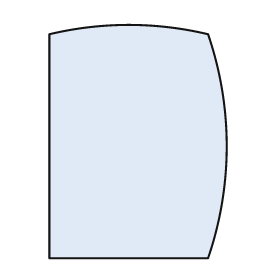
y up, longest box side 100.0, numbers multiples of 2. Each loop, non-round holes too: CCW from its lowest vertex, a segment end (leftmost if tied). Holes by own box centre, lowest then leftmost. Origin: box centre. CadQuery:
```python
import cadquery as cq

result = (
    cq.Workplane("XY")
    .moveTo(-38.0, -50.0)
    .lineTo(30.0, -50.0)
    .threePointArc((38.0, -2.0), (30.0, 46.0))
    .threePointArc((-4.0, 50.0), (-38.0, 46.0))
    .close()
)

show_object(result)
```